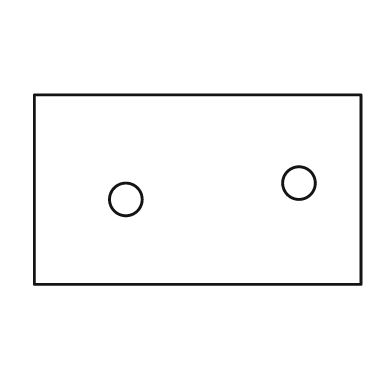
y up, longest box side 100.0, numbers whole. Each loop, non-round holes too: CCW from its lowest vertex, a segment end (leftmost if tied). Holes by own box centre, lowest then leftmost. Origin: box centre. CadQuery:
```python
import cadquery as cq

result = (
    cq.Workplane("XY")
    .moveTo(-50.0, -29.0)
    .lineTo(50.0, -29.0)
    .lineTo(50.0, 29.0)
    .lineTo(-50.0, 29.0)
    .close()
    .moveTo(-22.0, -3.0)
    .circle(5.0)
    .moveTo(31.0, 2.0)
    .circle(5.0)
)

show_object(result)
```